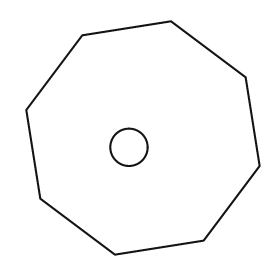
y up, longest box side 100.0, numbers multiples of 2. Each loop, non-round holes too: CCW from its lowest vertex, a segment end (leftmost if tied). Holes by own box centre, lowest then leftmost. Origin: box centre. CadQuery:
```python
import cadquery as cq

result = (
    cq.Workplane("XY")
    .moveTo(-12.0, -50.0)
    .lineTo(26.0, -44.0)
    .lineTo(50.0, -12.0)
    .lineTo(44.0, 26.0)
    .lineTo(12.0, 50.0)
    .lineTo(-26.0, 44.0)
    .lineTo(-50.0, 12.0)
    .lineTo(-44.0, -26.0)
    .close()
    .moveTo(-6.0, -4.0)
    .circle(8.0)
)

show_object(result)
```